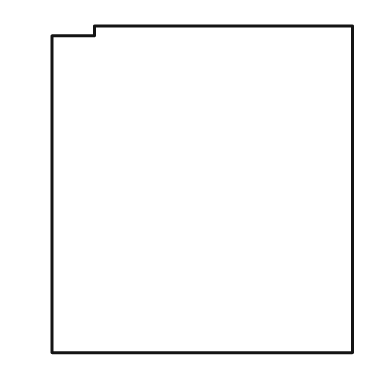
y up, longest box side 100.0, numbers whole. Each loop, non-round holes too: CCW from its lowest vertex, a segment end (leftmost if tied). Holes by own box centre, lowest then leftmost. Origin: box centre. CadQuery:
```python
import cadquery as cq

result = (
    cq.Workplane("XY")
    .moveTo(-46.0, -50.0)
    .lineTo(46.0, -50.0)
    .lineTo(46.0, 50.0)
    .lineTo(-33.0, 50.0)
    .lineTo(-33.0, 47.0)
    .lineTo(-46.0, 47.0)
    .close()
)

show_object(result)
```